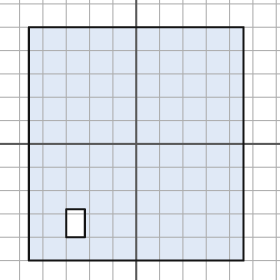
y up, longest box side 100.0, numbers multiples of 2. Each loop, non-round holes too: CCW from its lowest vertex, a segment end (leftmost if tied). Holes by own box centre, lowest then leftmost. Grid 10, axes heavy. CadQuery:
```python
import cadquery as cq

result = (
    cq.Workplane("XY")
    .moveTo(-46.0, -50.0)
    .lineTo(46.0, -50.0)
    .lineTo(46.0, 50.0)
    .lineTo(-46.0, 50.0)
    .close()
    .moveTo(-30.0, -40.0)
    .lineTo(-22.0, -40.0)
    .lineTo(-22.0, -28.0)
    .lineTo(-30.0, -28.0)
    .close()
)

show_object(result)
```